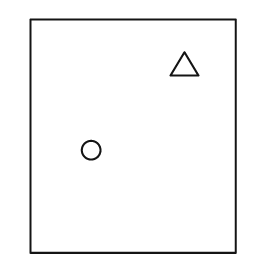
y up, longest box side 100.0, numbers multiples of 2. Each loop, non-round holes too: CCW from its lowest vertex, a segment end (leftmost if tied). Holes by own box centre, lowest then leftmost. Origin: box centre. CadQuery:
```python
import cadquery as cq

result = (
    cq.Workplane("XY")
    .moveTo(-44.0, -50.0)
    .lineTo(44.0, -50.0)
    .lineTo(44.0, 50.0)
    .lineTo(-44.0, 50.0)
    .close()
    .moveTo(-18.0, -6.0)
    .circle(4.0)
    .moveTo(16.0, 26.0)
    .lineTo(28.0, 26.0)
    .lineTo(22.0, 36.0)
    .close()
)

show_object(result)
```